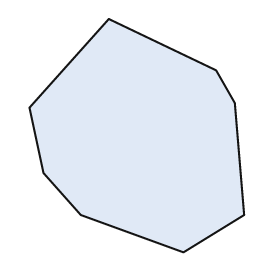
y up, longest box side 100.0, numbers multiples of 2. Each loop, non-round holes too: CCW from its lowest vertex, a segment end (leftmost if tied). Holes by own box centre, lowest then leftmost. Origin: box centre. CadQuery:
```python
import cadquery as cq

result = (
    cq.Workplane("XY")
    .moveTo(20.0, -50.0)
    .lineTo(46.0, -34.0)
    .lineTo(42.0, 14.0)
    .lineTo(34.0, 28.0)
    .lineTo(-12.0, 50.0)
    .lineTo(-46.0, 12.0)
    .lineTo(-40.0, -16.0)
    .lineTo(-24.0, -34.0)
    .close()
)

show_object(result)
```